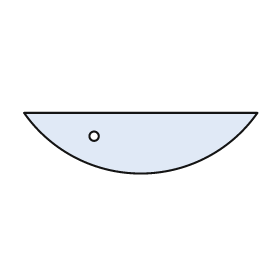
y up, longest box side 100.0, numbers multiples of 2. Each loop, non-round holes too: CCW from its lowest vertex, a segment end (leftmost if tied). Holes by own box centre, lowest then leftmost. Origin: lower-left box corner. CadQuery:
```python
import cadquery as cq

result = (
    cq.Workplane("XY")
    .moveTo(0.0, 26.0)
    .threePointArc((50.0, 0.0), (100.0, 26.0))
    .close()
    .moveTo(30.0, 16.0)
    .circle(2.0)
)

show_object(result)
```